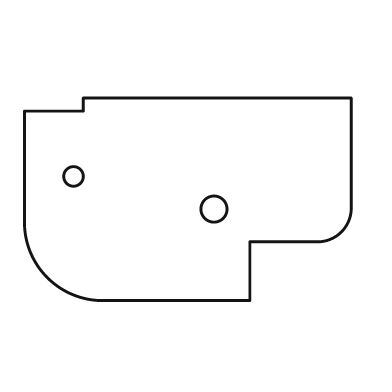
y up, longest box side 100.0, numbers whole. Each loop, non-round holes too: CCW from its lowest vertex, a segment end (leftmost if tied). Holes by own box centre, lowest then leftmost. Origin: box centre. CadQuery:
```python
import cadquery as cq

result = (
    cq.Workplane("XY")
    .moveTo(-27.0, -31.0)
    .lineTo(19.0, -31.0)
    .lineTo(19.0, -13.0)
    .lineTo(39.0, -13.0)
    .threePointArc((47.0, -10.0), (50.0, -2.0))
    .lineTo(50.0, 31.0)
    .lineTo(-32.0, 31.0)
    .lineTo(-32.0, 27.0)
    .lineTo(-50.0, 27.0)
    .lineTo(-50.0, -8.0)
    .threePointArc((-43.0, -24.0), (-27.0, -31.0))
    .close()
    .moveTo(8.0, -3.0)
    .circle(4.0)
    .moveTo(-35.0, 7.0)
    .circle(3.0)
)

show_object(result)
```